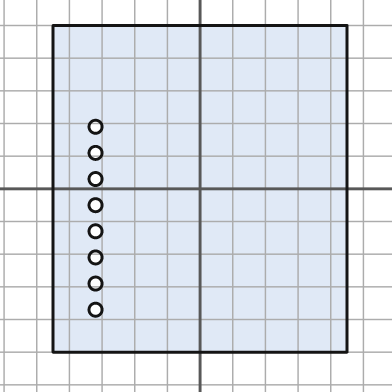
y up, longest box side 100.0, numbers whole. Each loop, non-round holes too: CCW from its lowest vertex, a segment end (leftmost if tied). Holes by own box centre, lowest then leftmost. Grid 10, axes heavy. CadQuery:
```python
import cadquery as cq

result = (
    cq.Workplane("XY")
    .moveTo(-45.0, -50.0)
    .lineTo(45.0, -50.0)
    .lineTo(45.0, 50.0)
    .lineTo(-45.0, 50.0)
    .close()
    .moveTo(-32.0, -37.0)
    .circle(2.0)
    .moveTo(-32.0, -29.0)
    .circle(2.0)
    .moveTo(-32.0, -21.0)
    .circle(2.0)
    .moveTo(-32.0, -13.0)
    .circle(2.0)
    .moveTo(-32.0, -5.0)
    .circle(2.0)
    .moveTo(-32.0, 3.0)
    .circle(2.0)
    .moveTo(-32.0, 11.0)
    .circle(2.0)
    .moveTo(-32.0, 19.0)
    .circle(2.0)
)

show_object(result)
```